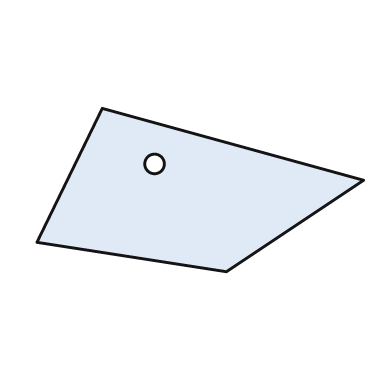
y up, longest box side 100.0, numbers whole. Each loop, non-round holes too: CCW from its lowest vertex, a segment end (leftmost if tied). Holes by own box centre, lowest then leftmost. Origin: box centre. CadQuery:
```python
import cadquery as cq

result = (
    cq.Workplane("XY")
    .moveTo(8.0, -25.0)
    .lineTo(50.0, 3.0)
    .lineTo(-30.0, 25.0)
    .lineTo(-50.0, -16.0)
    .close()
    .moveTo(-14.0, 8.0)
    .circle(3.0)
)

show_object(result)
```